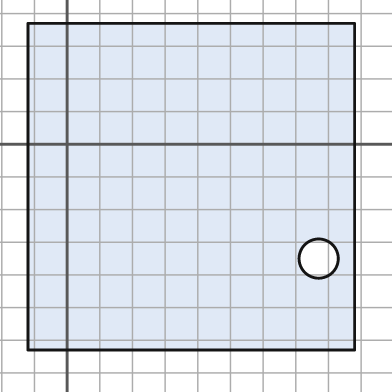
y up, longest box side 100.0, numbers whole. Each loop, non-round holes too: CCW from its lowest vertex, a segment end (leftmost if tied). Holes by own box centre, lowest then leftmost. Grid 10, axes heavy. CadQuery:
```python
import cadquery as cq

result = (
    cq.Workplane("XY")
    .moveTo(-12.0, -63.0)
    .lineTo(88.0, -63.0)
    .lineTo(88.0, 37.0)
    .lineTo(-12.0, 37.0)
    .close()
    .moveTo(77.0, -35.0)
    .circle(6.0)
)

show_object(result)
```